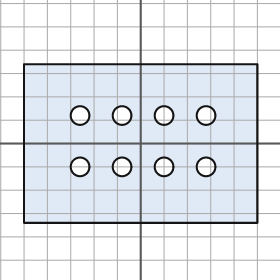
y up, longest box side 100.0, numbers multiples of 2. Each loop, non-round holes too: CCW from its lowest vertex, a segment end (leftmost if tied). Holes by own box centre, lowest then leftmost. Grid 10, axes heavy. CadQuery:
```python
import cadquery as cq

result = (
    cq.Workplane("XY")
    .moveTo(-50.0, -34.0)
    .lineTo(50.0, -34.0)
    .lineTo(50.0, 34.0)
    .lineTo(-50.0, 34.0)
    .close()
    .moveTo(-26.0, -10.0)
    .circle(4.0)
    .moveTo(-8.0, -10.0)
    .circle(4.0)
    .moveTo(10.0, -10.0)
    .circle(4.0)
    .moveTo(28.0, -10.0)
    .circle(4.0)
    .moveTo(-26.0, 12.0)
    .circle(4.0)
    .moveTo(-8.0, 12.0)
    .circle(4.0)
    .moveTo(10.0, 12.0)
    .circle(4.0)
    .moveTo(28.0, 12.0)
    .circle(4.0)
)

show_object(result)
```